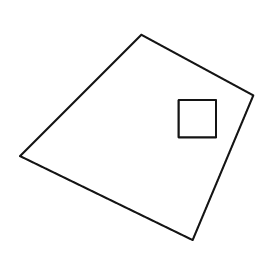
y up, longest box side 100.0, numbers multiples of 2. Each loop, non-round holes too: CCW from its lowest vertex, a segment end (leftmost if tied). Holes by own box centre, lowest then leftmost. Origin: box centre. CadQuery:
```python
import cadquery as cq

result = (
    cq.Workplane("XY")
    .moveTo(24.0, -44.0)
    .lineTo(50.0, 18.0)
    .lineTo(2.0, 44.0)
    .lineTo(-50.0, -8.0)
    .close()
    .moveTo(18.0, 0.0)
    .lineTo(34.0, 0.0)
    .lineTo(34.0, 16.0)
    .lineTo(18.0, 16.0)
    .close()
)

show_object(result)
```